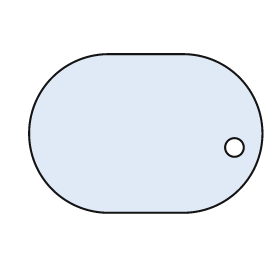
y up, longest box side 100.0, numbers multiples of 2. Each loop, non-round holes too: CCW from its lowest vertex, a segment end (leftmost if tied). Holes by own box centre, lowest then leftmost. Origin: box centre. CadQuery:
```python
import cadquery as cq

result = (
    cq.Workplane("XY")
    .moveTo(-16.0, -34.0)
    .lineTo(16.0, -34.0)
    .threePointArc((50.0, 0.0), (16.0, 34.0))
    .lineTo(-16.0, 34.0)
    .threePointArc((-50.0, 0.0), (-16.0, -34.0))
    .close()
    .moveTo(38.0, -6.0)
    .circle(4.0)
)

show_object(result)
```